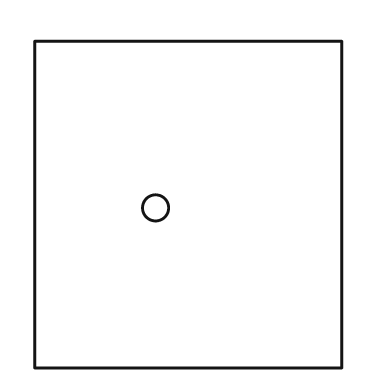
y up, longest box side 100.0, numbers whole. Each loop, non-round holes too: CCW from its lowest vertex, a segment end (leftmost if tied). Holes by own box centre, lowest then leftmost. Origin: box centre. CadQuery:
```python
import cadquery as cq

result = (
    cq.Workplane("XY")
    .moveTo(-47.0, -50.0)
    .lineTo(47.0, -50.0)
    .lineTo(47.0, 50.0)
    .lineTo(-47.0, 50.0)
    .close()
    .moveTo(-10.0, -1.0)
    .circle(4.0)
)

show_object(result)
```